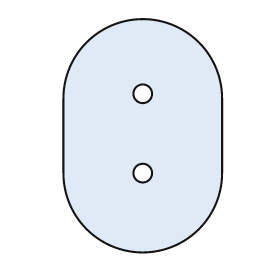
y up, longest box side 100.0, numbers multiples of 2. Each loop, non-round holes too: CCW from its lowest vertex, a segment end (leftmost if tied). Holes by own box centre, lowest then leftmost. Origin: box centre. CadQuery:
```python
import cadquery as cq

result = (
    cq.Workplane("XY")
    .moveTo(-34.0, -16.0)
    .threePointArc((0.0, -50.0), (34.0, -16.0))
    .lineTo(34.0, 16.0)
    .threePointArc((0.0, 50.0), (-34.0, 16.0))
    .close()
    .moveTo(0.0, -16.0)
    .circle(4.0)
    .moveTo(0.0, 18.0)
    .circle(4.0)
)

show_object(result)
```